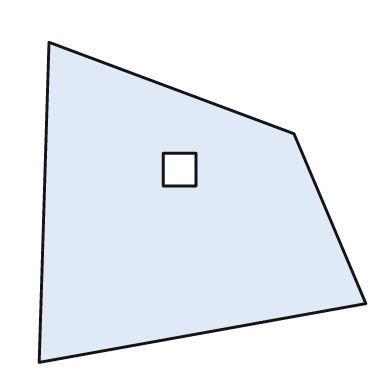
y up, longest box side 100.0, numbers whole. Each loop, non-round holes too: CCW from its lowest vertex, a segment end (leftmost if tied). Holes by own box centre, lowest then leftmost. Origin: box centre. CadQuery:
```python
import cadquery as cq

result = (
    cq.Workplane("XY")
    .moveTo(-50.0, -49.0)
    .lineTo(50.0, -31.0)
    .lineTo(28.0, 21.0)
    .lineTo(-47.0, 49.0)
    .close()
    .moveTo(-12.0, 5.0)
    .lineTo(-2.0, 5.0)
    .lineTo(-2.0, 15.0)
    .lineTo(-12.0, 15.0)
    .close()
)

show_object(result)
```